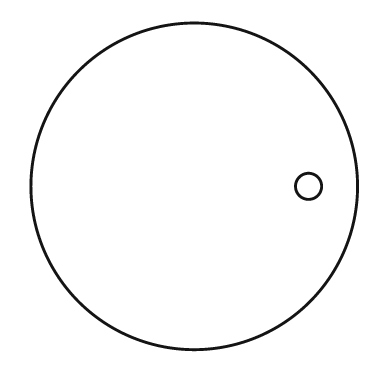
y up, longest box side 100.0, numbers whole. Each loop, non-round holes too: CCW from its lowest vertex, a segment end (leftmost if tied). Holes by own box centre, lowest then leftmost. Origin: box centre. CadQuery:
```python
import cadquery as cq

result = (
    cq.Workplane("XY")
    .moveTo(0.0, 0.0)
    .circle(50.0)
    .moveTo(35.0, 0.0)
    .circle(4.0)
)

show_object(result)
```